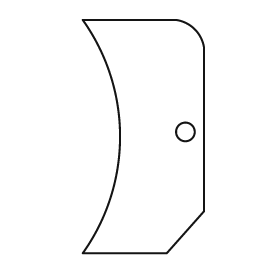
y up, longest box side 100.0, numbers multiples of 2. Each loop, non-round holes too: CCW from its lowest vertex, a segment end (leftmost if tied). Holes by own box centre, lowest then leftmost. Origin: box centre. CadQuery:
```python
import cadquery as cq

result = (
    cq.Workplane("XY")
    .moveTo(-26.0, -50.0)
    .lineTo(10.0, -50.0)
    .lineTo(26.0, -32.0)
    .lineTo(26.0, 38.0)
    .threePointArc((22.0, 46.0), (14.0, 50.0))
    .lineTo(-26.0, 50.0)
    .threePointArc((-10.0, 0.0), (-26.0, -50.0))
    .close()
    .moveTo(18.0, 2.0)
    .circle(4.0)
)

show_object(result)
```